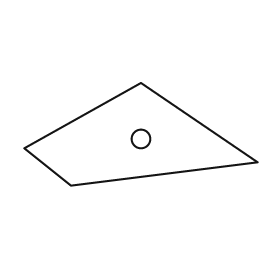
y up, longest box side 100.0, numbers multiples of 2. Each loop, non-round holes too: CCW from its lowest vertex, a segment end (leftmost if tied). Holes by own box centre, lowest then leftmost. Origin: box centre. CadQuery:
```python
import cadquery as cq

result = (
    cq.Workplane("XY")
    .moveTo(-30.0, -22.0)
    .lineTo(50.0, -12.0)
    .lineTo(0.0, 22.0)
    .lineTo(-50.0, -6.0)
    .close()
    .moveTo(0.0, -2.0)
    .circle(4.0)
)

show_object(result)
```